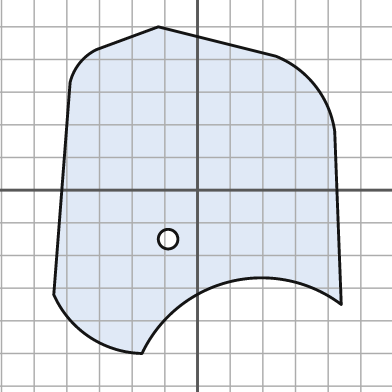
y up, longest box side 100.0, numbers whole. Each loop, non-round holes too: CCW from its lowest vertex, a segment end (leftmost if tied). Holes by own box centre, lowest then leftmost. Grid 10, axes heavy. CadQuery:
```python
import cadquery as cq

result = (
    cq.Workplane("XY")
    .moveTo(-17.0, -50.0)
    .threePointArc((10.0, -28.0), (44.0, -35.0))
    .lineTo(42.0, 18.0)
    .threePointArc((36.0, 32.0), (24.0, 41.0))
    .lineTo(-12.0, 50.0)
    .lineTo(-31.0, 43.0)
    .threePointArc((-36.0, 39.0), (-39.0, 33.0))
    .lineTo(-44.0, -32.0)
    .threePointArc((-33.0, -45.0), (-17.0, -50.0))
    .close()
    .moveTo(-9.0, -15.0)
    .circle(3.0)
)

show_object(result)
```